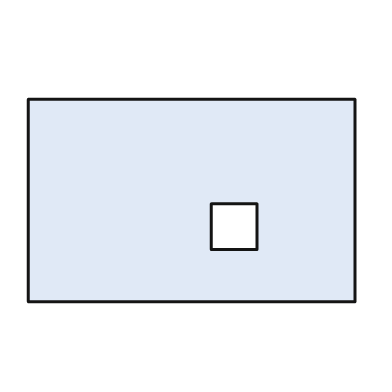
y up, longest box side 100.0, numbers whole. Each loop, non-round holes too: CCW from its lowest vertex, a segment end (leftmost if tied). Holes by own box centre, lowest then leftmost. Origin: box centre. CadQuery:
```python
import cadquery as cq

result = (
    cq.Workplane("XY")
    .moveTo(-50.0, -31.0)
    .lineTo(50.0, -31.0)
    .lineTo(50.0, 31.0)
    .lineTo(-50.0, 31.0)
    .close()
    .moveTo(6.0, -15.0)
    .lineTo(20.0, -15.0)
    .lineTo(20.0, -1.0)
    .lineTo(6.0, -1.0)
    .close()
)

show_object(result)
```